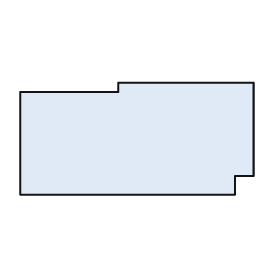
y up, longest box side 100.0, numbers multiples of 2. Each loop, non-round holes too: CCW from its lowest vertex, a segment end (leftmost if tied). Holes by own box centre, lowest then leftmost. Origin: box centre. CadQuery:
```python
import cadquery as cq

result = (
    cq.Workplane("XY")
    .moveTo(-50.0, -24.0)
    .lineTo(42.0, -24.0)
    .lineTo(42.0, -16.0)
    .lineTo(50.0, -16.0)
    .lineTo(50.0, 24.0)
    .lineTo(-8.0, 24.0)
    .lineTo(-8.0, 20.0)
    .lineTo(-50.0, 20.0)
    .close()
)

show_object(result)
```